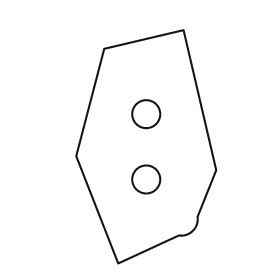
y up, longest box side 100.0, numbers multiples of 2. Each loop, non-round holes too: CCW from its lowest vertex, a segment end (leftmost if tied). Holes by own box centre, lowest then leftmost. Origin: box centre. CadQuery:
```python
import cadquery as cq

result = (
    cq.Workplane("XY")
    .moveTo(-12.0, -50.0)
    .lineTo(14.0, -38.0)
    .threePointArc((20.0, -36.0), (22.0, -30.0))
    .lineTo(30.0, -10.0)
    .lineTo(16.0, 50.0)
    .lineTo(-18.0, 42.0)
    .lineTo(-30.0, -4.0)
    .close()
    .moveTo(0.0, -14.0)
    .circle(6.0)
    .moveTo(0.0, 14.0)
    .circle(6.0)
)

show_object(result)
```